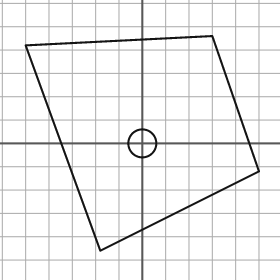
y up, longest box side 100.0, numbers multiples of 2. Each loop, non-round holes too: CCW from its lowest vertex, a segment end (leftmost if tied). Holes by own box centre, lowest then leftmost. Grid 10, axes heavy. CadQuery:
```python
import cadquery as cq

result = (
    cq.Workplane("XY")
    .moveTo(-18.0, -46.0)
    .lineTo(50.0, -12.0)
    .lineTo(30.0, 46.0)
    .lineTo(-50.0, 42.0)
    .close()
    .moveTo(0.0, 0.0)
    .circle(6.0)
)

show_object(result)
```